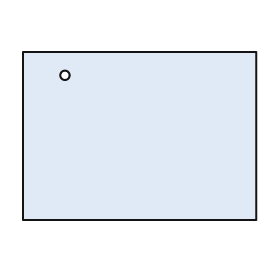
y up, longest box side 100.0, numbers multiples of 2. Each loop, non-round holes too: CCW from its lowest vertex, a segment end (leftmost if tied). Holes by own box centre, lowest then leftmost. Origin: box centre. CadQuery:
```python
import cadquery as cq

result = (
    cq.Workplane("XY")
    .moveTo(-50.0, -36.0)
    .lineTo(50.0, -36.0)
    .lineTo(50.0, 36.0)
    .lineTo(-50.0, 36.0)
    .close()
    .moveTo(-32.0, 26.0)
    .circle(2.0)
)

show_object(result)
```